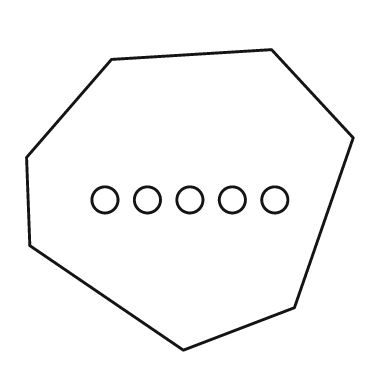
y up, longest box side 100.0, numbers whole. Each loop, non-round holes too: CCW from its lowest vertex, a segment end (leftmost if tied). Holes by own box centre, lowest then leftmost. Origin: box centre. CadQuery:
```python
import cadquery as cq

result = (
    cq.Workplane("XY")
    .moveTo(-2.0, -46.0)
    .lineTo(32.0, -33.0)
    .lineTo(50.0, 19.0)
    .lineTo(25.0, 46.0)
    .lineTo(-24.0, 43.0)
    .lineTo(-50.0, 13.0)
    .lineTo(-49.0, -14.0)
    .close()
    .moveTo(-26.0, 0.0)
    .circle(4.0)
    .moveTo(-13.0, 0.0)
    .circle(4.0)
    .moveTo(0.0, 0.0)
    .circle(4.0)
    .moveTo(13.0, 0.0)
    .circle(4.0)
    .moveTo(26.0, 0.0)
    .circle(4.0)
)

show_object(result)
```